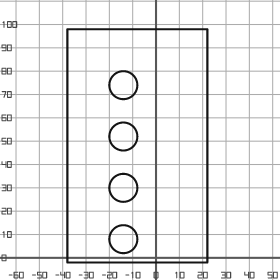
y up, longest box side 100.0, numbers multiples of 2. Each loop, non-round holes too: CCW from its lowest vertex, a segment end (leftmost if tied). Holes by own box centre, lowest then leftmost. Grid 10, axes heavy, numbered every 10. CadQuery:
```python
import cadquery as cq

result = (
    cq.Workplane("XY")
    .moveTo(-38.0, -2.0)
    .lineTo(22.0, -2.0)
    .lineTo(22.0, 98.0)
    .lineTo(-38.0, 98.0)
    .close()
    .moveTo(-14.0, 8.0)
    .circle(6.0)
    .moveTo(-14.0, 30.0)
    .circle(6.0)
    .moveTo(-14.0, 52.0)
    .circle(6.0)
    .moveTo(-14.0, 74.0)
    .circle(6.0)
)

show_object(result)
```